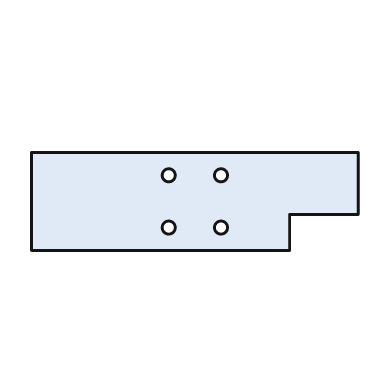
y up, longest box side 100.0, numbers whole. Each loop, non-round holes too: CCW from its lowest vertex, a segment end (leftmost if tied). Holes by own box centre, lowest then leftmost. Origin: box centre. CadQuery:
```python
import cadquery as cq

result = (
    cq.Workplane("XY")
    .moveTo(-50.0, -15.0)
    .lineTo(29.0, -15.0)
    .lineTo(29.0, -4.0)
    .lineTo(50.0, -4.0)
    .lineTo(50.0, 15.0)
    .lineTo(-50.0, 15.0)
    .close()
    .moveTo(-8.0, -8.0)
    .circle(2.0)
    .moveTo(8.0, -8.0)
    .circle(2.0)
    .moveTo(-8.0, 8.0)
    .circle(2.0)
    .moveTo(8.0, 8.0)
    .circle(2.0)
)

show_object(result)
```